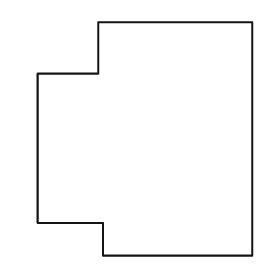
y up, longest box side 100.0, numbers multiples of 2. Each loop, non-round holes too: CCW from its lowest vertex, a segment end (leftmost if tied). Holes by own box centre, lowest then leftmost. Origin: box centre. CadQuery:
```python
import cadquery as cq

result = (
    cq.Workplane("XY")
    .moveTo(-18.0, -50.0)
    .lineTo(46.0, -50.0)
    .lineTo(46.0, 50.0)
    .lineTo(-20.0, 50.0)
    .lineTo(-20.0, 28.0)
    .lineTo(-46.0, 28.0)
    .lineTo(-46.0, -36.0)
    .lineTo(-18.0, -36.0)
    .close()
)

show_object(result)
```